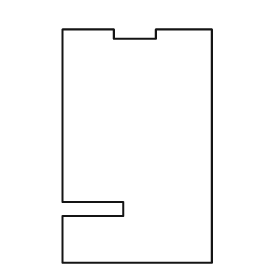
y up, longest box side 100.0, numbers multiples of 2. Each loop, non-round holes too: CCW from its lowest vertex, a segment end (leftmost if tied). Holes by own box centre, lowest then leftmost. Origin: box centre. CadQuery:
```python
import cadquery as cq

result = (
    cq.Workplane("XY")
    .moveTo(-32.0, -50.0)
    .lineTo(32.0, -50.0)
    .lineTo(32.0, 50.0)
    .lineTo(8.0, 50.0)
    .lineTo(8.0, 46.0)
    .lineTo(-10.0, 46.0)
    .lineTo(-10.0, 50.0)
    .lineTo(-32.0, 50.0)
    .lineTo(-32.0, -24.0)
    .lineTo(-6.0, -24.0)
    .lineTo(-6.0, -30.0)
    .lineTo(-32.0, -30.0)
    .close()
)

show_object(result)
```